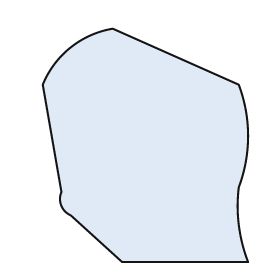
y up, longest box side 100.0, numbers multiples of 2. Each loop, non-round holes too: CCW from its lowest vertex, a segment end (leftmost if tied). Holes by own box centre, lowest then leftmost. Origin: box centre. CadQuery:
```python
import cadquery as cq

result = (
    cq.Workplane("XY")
    .moveTo(-10.0, -50.0)
    .lineTo(44.0, -50.0)
    .threePointArc((40.0, -34.0), (40.0, -18.0))
    .threePointArc((44.0, 4.0), (40.0, 26.0))
    .lineTo(-14.0, 50.0)
    .threePointArc((-32.0, 42.0), (-44.0, 26.0))
    .lineTo(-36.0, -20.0)
    .threePointArc((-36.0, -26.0), (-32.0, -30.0))
    .close()
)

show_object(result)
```